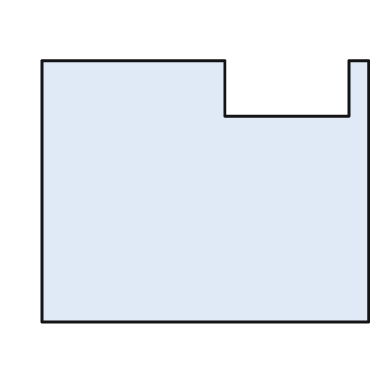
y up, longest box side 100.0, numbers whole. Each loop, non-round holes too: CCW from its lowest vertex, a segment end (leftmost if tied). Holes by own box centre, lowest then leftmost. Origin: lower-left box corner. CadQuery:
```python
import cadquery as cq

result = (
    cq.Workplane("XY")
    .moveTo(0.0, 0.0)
    .lineTo(100.0, 0.0)
    .lineTo(100.0, 80.0)
    .lineTo(94.0, 80.0)
    .lineTo(94.0, 63.0)
    .lineTo(56.0, 63.0)
    .lineTo(56.0, 80.0)
    .lineTo(0.0, 80.0)
    .close()
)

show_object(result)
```